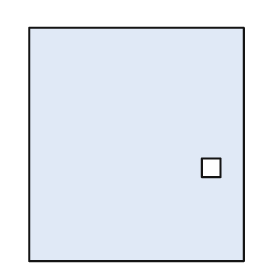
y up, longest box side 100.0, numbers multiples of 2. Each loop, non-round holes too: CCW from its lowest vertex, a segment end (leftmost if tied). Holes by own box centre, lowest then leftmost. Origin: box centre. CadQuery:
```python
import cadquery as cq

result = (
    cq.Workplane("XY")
    .moveTo(-46.0, -50.0)
    .lineTo(46.0, -50.0)
    .lineTo(46.0, 50.0)
    .lineTo(-46.0, 50.0)
    .close()
    .moveTo(28.0, -14.0)
    .lineTo(36.0, -14.0)
    .lineTo(36.0, -6.0)
    .lineTo(28.0, -6.0)
    .close()
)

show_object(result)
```